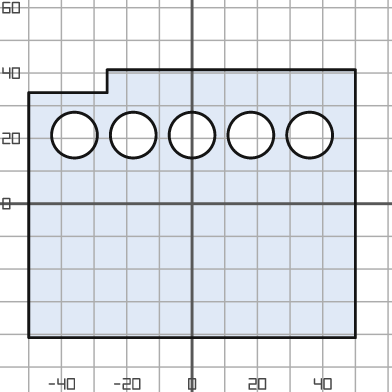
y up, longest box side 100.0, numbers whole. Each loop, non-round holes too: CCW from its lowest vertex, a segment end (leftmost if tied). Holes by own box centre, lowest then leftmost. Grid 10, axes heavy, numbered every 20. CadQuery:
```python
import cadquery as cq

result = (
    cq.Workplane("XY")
    .moveTo(-50.0, -41.0)
    .lineTo(50.0, -41.0)
    .lineTo(50.0, 41.0)
    .lineTo(-26.0, 41.0)
    .lineTo(-26.0, 34.0)
    .lineTo(-50.0, 34.0)
    .close()
    .moveTo(-36.0, 21.0)
    .circle(7.0)
    .moveTo(-18.0, 21.0)
    .circle(7.0)
    .moveTo(0.0, 21.0)
    .circle(7.0)
    .moveTo(18.0, 21.0)
    .circle(7.0)
    .moveTo(36.0, 21.0)
    .circle(7.0)
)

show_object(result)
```